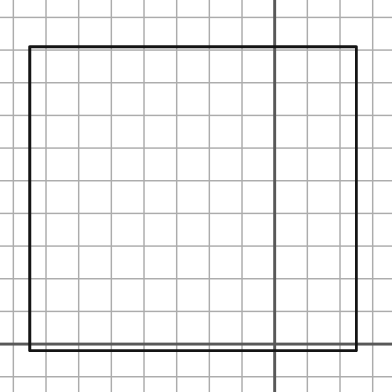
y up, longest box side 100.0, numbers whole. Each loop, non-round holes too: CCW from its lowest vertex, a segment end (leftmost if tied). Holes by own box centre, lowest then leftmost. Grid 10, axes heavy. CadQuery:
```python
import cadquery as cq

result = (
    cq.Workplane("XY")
    .moveTo(-75.0, -2.0)
    .lineTo(25.0, -2.0)
    .lineTo(25.0, 91.0)
    .lineTo(-75.0, 91.0)
    .close()
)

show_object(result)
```